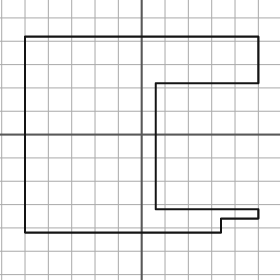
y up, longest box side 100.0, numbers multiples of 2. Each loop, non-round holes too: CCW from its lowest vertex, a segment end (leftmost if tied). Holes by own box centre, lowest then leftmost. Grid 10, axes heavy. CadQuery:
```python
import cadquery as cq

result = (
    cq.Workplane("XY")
    .moveTo(-50.0, -42.0)
    .lineTo(34.0, -42.0)
    .lineTo(34.0, -36.0)
    .lineTo(50.0, -36.0)
    .lineTo(50.0, -32.0)
    .lineTo(6.0, -32.0)
    .lineTo(6.0, 22.0)
    .lineTo(50.0, 22.0)
    .lineTo(50.0, 42.0)
    .lineTo(-50.0, 42.0)
    .close()
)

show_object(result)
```